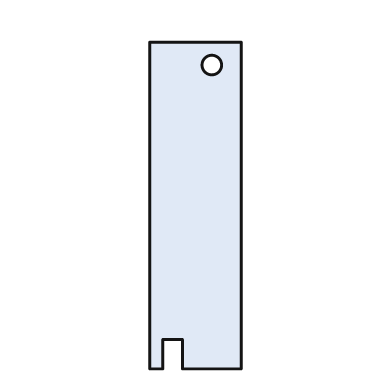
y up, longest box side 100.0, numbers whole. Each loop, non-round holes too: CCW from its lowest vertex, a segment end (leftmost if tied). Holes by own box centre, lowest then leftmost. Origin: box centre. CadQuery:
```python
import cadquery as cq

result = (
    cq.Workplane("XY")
    .moveTo(-14.0, -50.0)
    .lineTo(-10.0, -50.0)
    .lineTo(-10.0, -41.0)
    .lineTo(-4.0, -41.0)
    .lineTo(-4.0, -50.0)
    .lineTo(14.0, -50.0)
    .lineTo(14.0, 50.0)
    .lineTo(-14.0, 50.0)
    .close()
    .moveTo(5.0, 43.0)
    .circle(3.0)
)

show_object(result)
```